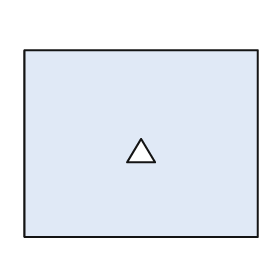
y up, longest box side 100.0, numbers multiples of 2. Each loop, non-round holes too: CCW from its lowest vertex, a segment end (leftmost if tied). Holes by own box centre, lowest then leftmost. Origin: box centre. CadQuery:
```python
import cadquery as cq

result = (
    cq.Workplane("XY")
    .moveTo(-50.0, -40.0)
    .lineTo(50.0, -40.0)
    .lineTo(50.0, 40.0)
    .lineTo(-50.0, 40.0)
    .close()
    .moveTo(-6.0, -8.0)
    .lineTo(6.0, -8.0)
    .lineTo(0.0, 2.0)
    .close()
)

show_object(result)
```